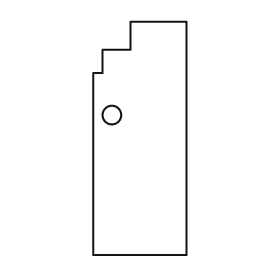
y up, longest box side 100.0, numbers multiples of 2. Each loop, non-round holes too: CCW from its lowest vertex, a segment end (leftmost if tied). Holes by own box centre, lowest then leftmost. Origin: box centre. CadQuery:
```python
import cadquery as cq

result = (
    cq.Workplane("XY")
    .moveTo(-20.0, -50.0)
    .lineTo(20.0, -50.0)
    .lineTo(20.0, 50.0)
    .lineTo(-4.0, 50.0)
    .lineTo(-4.0, 38.0)
    .lineTo(-16.0, 38.0)
    .lineTo(-16.0, 28.0)
    .lineTo(-20.0, 28.0)
    .close()
    .moveTo(-12.0, 10.0)
    .circle(4.0)
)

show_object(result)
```